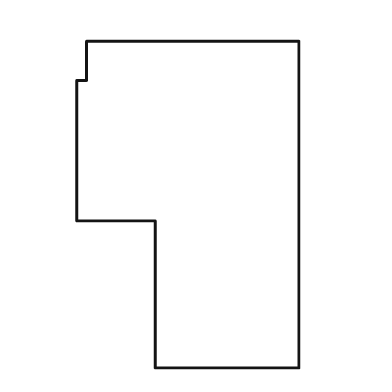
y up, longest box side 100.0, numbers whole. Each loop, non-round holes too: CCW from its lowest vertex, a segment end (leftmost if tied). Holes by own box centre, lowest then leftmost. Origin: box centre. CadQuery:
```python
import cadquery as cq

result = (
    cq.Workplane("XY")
    .moveTo(-10.0, -50.0)
    .lineTo(34.0, -50.0)
    .lineTo(34.0, 50.0)
    .lineTo(-31.0, 50.0)
    .lineTo(-31.0, 38.0)
    .lineTo(-34.0, 38.0)
    .lineTo(-34.0, -5.0)
    .lineTo(-10.0, -5.0)
    .close()
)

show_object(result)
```